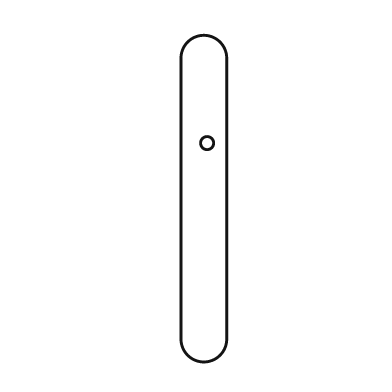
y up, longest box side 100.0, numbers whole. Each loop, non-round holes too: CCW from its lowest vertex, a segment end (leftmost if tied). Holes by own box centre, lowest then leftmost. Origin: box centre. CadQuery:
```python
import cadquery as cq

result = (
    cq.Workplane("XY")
    .moveTo(-7.0, -43.0)
    .threePointArc((0.0, -50.0), (7.0, -43.0))
    .lineTo(7.0, 43.0)
    .threePointArc((0.0, 50.0), (-7.0, 43.0))
    .close()
    .moveTo(1.0, 17.0)
    .circle(2.0)
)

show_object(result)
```